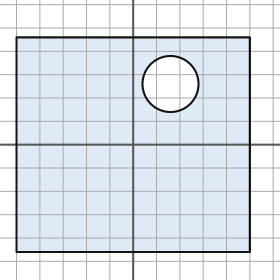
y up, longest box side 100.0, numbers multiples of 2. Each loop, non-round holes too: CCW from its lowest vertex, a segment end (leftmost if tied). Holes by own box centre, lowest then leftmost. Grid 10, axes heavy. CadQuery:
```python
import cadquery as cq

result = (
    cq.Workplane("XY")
    .moveTo(-50.0, -46.0)
    .lineTo(50.0, -46.0)
    .lineTo(50.0, 46.0)
    .lineTo(-50.0, 46.0)
    .close()
    .moveTo(16.0, 26.0)
    .circle(12.0)
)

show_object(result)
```